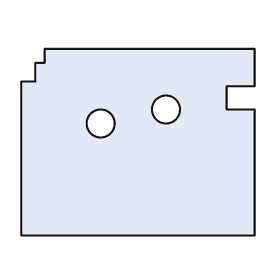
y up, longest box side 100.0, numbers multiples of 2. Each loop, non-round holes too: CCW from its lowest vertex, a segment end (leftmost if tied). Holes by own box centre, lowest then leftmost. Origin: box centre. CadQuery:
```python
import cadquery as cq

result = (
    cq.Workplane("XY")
    .moveTo(-50.0, -40.0)
    .lineTo(50.0, -40.0)
    .lineTo(50.0, 14.0)
    .lineTo(38.0, 14.0)
    .lineTo(38.0, 24.0)
    .lineTo(50.0, 24.0)
    .lineTo(50.0, 40.0)
    .lineTo(-40.0, 40.0)
    .lineTo(-40.0, 34.0)
    .lineTo(-44.0, 34.0)
    .lineTo(-44.0, 26.0)
    .lineTo(-50.0, 26.0)
    .close()
    .moveTo(-16.0, 8.0)
    .circle(6.0)
    .moveTo(12.0, 14.0)
    .circle(6.0)
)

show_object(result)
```